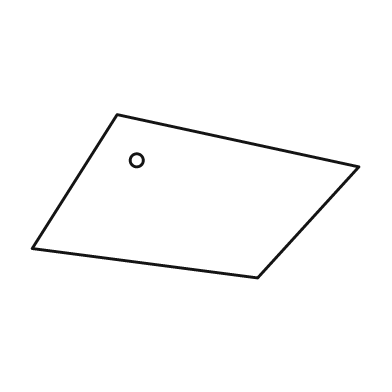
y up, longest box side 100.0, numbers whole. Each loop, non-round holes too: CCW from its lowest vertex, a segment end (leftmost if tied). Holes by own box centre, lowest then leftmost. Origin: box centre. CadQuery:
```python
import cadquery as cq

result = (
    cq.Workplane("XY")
    .moveTo(19.0, -25.0)
    .lineTo(50.0, 9.0)
    .lineTo(-24.0, 25.0)
    .lineTo(-50.0, -16.0)
    .close()
    .moveTo(-18.0, 11.0)
    .circle(2.0)
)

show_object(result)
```